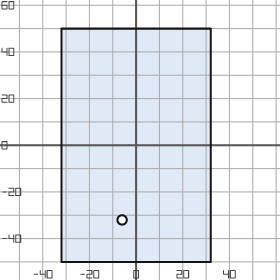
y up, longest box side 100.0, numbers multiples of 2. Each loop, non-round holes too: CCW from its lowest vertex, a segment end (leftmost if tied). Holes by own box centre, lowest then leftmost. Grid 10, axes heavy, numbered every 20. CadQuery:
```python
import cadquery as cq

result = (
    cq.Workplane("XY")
    .moveTo(-32.0, -50.0)
    .lineTo(32.0, -50.0)
    .lineTo(32.0, 50.0)
    .lineTo(-32.0, 50.0)
    .close()
    .moveTo(-6.0, -32.0)
    .circle(2.0)
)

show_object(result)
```